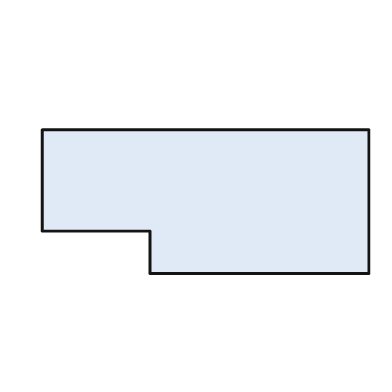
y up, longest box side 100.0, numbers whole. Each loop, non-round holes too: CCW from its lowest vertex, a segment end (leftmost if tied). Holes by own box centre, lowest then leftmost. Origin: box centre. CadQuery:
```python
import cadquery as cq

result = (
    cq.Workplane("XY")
    .moveTo(-17.0, -22.0)
    .lineTo(50.0, -22.0)
    .lineTo(50.0, 22.0)
    .lineTo(-50.0, 22.0)
    .lineTo(-50.0, -9.0)
    .lineTo(-17.0, -9.0)
    .close()
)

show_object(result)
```